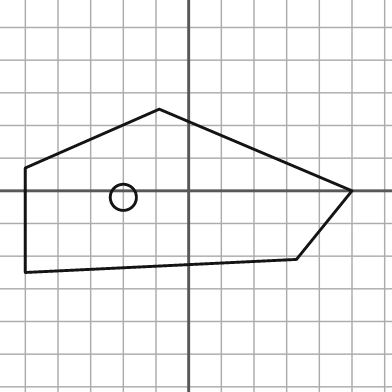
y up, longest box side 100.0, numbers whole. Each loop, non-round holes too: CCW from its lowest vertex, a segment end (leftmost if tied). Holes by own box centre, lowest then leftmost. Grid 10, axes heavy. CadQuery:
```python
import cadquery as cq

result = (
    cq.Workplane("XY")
    .moveTo(-50.0, -25.0)
    .lineTo(33.0, -21.0)
    .lineTo(50.0, 0.0)
    .lineTo(-9.0, 25.0)
    .lineTo(-50.0, 7.0)
    .close()
    .moveTo(-20.0, -2.0)
    .circle(4.0)
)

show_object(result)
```